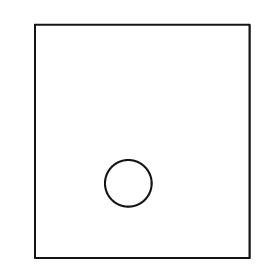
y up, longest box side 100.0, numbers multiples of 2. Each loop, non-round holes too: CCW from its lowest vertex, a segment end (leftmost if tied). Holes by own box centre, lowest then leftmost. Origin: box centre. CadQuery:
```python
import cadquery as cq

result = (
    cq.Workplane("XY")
    .moveTo(-46.0, -50.0)
    .lineTo(46.0, -50.0)
    .lineTo(46.0, 50.0)
    .lineTo(-46.0, 50.0)
    .close()
    .moveTo(-6.0, -18.0)
    .circle(10.0)
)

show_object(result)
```